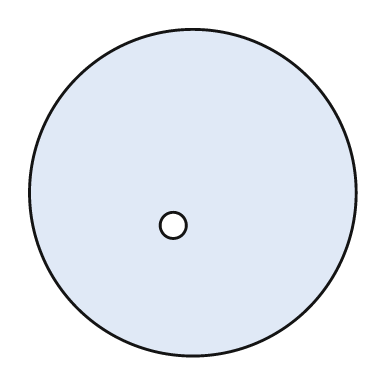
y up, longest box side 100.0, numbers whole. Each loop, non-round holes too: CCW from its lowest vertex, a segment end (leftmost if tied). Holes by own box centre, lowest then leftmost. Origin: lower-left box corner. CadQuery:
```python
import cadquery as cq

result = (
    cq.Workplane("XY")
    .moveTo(50.0, 50.0)
    .circle(50.0)
    .moveTo(44.0, 40.0)
    .circle(4.0)
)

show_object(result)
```